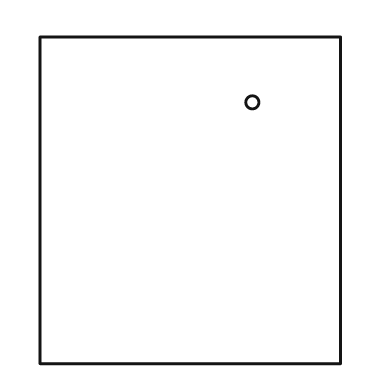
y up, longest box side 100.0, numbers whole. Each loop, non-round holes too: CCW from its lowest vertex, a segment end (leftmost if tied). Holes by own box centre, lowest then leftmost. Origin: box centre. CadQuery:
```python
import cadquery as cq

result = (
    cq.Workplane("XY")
    .moveTo(-46.0, -50.0)
    .lineTo(46.0, -50.0)
    .lineTo(46.0, 50.0)
    .lineTo(-46.0, 50.0)
    .close()
    .moveTo(19.0, 30.0)
    .circle(2.0)
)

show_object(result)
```